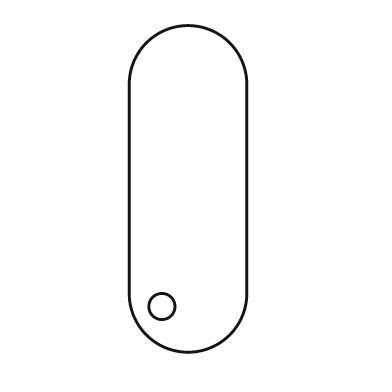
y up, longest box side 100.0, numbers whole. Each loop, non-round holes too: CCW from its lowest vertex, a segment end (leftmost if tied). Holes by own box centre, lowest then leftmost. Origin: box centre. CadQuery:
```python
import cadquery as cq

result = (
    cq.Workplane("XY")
    .moveTo(-18.0, -32.0)
    .threePointArc((0.0, -50.0), (18.0, -32.0))
    .lineTo(18.0, 32.0)
    .threePointArc((0.0, 50.0), (-18.0, 32.0))
    .close()
    .moveTo(-8.0, -36.0)
    .circle(4.0)
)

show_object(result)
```